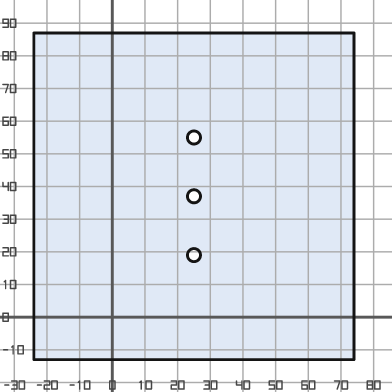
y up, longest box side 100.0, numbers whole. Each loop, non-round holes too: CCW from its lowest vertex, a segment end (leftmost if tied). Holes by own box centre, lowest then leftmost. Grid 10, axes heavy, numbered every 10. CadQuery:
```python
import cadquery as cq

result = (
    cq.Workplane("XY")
    .moveTo(-24.0, -13.0)
    .lineTo(74.0, -13.0)
    .lineTo(74.0, 87.0)
    .lineTo(-24.0, 87.0)
    .close()
    .moveTo(25.0, 19.0)
    .circle(2.0)
    .moveTo(25.0, 37.0)
    .circle(2.0)
    .moveTo(25.0, 55.0)
    .circle(2.0)
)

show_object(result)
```